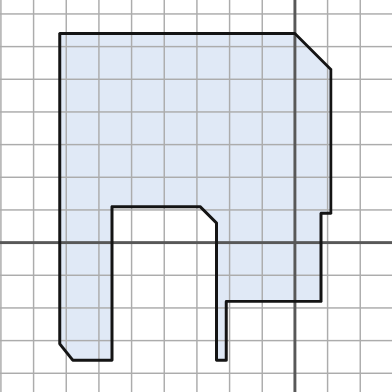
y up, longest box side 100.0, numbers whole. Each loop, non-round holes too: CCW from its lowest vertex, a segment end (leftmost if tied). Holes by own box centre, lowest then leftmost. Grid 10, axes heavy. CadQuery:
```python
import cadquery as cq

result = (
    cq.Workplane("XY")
    .moveTo(-68.0, -36.0)
    .lineTo(-56.0, -36.0)
    .lineTo(-56.0, 11.0)
    .lineTo(-29.0, 11.0)
    .lineTo(-24.0, 6.0)
    .lineTo(-24.0, -36.0)
    .lineTo(-21.0, -36.0)
    .lineTo(-21.0, -18.0)
    .lineTo(8.0, -18.0)
    .lineTo(8.0, 9.0)
    .lineTo(11.0, 9.0)
    .lineTo(11.0, 53.0)
    .lineTo(0.0, 64.0)
    .lineTo(-72.0, 64.0)
    .lineTo(-72.0, -31.0)
    .close()
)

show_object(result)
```